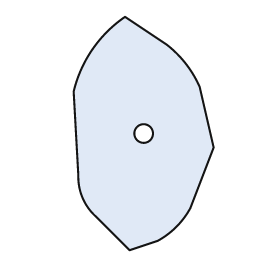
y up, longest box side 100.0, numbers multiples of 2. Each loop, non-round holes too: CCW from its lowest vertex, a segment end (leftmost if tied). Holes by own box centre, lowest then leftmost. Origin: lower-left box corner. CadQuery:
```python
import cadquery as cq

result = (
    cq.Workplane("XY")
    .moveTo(24.0, 0.0)
    .lineTo(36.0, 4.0)
    .threePointArc((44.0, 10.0), (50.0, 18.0))
    .lineTo(60.0, 44.0)
    .lineTo(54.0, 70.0)
    .threePointArc((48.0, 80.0), (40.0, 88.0))
    .lineTo(22.0, 100.0)
    .threePointArc((8.0, 86.0), (0.0, 68.0))
    .lineTo(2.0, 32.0)
    .threePointArc((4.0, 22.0), (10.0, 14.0))
    .close()
    .moveTo(30.0, 50.0)
    .circle(4.0)
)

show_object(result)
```